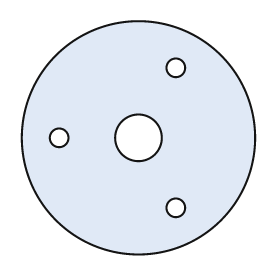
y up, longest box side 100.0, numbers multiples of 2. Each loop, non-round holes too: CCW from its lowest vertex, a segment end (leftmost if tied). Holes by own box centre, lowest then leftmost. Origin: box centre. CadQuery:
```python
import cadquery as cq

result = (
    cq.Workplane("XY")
    .moveTo(0.0, 0.0)
    .circle(50.0)
    .moveTo(16.0, -30.0)
    .circle(4.0)
    .moveTo(-34.0, 0.0)
    .circle(4.0)
    .moveTo(0.0, 0.0)
    .circle(10.0)
    .moveTo(16.0, 30.0)
    .circle(4.0)
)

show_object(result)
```